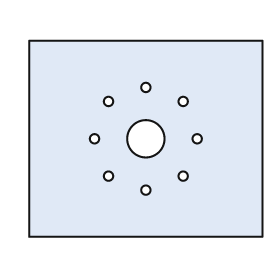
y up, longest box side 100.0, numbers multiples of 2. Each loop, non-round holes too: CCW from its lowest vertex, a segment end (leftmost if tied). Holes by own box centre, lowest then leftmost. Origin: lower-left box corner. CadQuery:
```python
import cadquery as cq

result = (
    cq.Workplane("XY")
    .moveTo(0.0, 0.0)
    .lineTo(100.0, 0.0)
    .lineTo(100.0, 84.0)
    .lineTo(0.0, 84.0)
    .close()
    .moveTo(50.0, 20.0)
    .circle(2.0)
    .moveTo(34.0, 26.0)
    .circle(2.0)
    .moveTo(66.0, 26.0)
    .circle(2.0)
    .moveTo(28.0, 42.0)
    .circle(2.0)
    .moveTo(50.0, 42.0)
    .circle(8.0)
    .moveTo(72.0, 42.0)
    .circle(2.0)
    .moveTo(34.0, 58.0)
    .circle(2.0)
    .moveTo(66.0, 58.0)
    .circle(2.0)
    .moveTo(50.0, 64.0)
    .circle(2.0)
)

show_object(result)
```